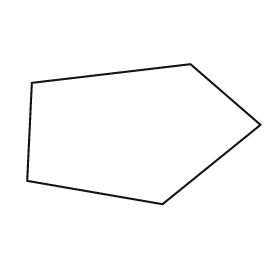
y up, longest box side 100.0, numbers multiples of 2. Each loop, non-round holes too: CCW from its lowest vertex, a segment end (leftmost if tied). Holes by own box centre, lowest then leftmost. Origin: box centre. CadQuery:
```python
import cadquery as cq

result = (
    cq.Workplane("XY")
    .moveTo(8.0, -30.0)
    .lineTo(50.0, 4.0)
    .lineTo(20.0, 30.0)
    .lineTo(-48.0, 22.0)
    .lineTo(-50.0, -20.0)
    .close()
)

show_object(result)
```